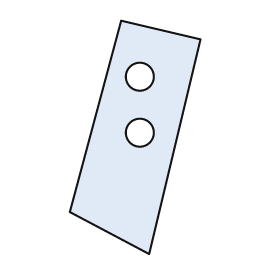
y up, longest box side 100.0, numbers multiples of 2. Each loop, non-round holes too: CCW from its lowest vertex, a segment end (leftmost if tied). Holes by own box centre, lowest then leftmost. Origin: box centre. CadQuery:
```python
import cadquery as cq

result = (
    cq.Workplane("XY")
    .moveTo(6.0, -50.0)
    .lineTo(28.0, 42.0)
    .lineTo(-6.0, 50.0)
    .lineTo(-28.0, -32.0)
    .close()
    .moveTo(2.0, 2.0)
    .circle(6.0)
    .moveTo(2.0, 26.0)
    .circle(6.0)
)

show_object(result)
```